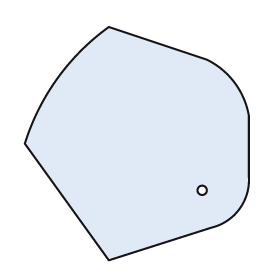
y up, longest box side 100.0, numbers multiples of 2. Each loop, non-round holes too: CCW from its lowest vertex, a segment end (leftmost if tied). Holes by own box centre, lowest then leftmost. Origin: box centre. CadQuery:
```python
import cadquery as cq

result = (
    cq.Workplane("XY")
    .moveTo(-12.0, -50.0)
    .lineTo(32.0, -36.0)
    .threePointArc((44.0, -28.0), (48.0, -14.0))
    .lineTo(48.0, 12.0)
    .threePointArc((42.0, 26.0), (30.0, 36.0))
    .lineTo(-12.0, 50.0)
    .threePointArc((-34.0, 28.0), (-48.0, 0.0))
    .close()
    .moveTo(28.0, -20.0)
    .circle(2.0)
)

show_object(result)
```